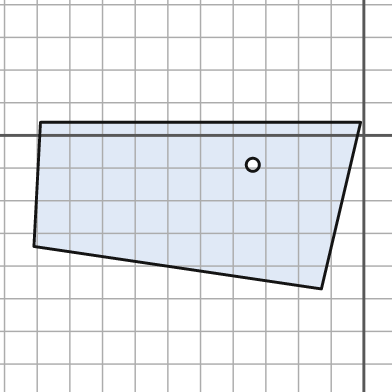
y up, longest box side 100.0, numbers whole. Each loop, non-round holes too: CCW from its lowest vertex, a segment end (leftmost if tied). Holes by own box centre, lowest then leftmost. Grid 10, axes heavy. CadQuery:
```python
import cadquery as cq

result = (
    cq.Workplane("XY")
    .moveTo(-13.0, -47.0)
    .lineTo(-1.0, 4.0)
    .lineTo(-99.0, 4.0)
    .lineTo(-101.0, -34.0)
    .close()
    .moveTo(-34.0, -9.0)
    .circle(2.0)
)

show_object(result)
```